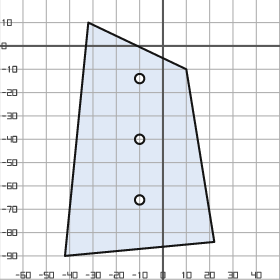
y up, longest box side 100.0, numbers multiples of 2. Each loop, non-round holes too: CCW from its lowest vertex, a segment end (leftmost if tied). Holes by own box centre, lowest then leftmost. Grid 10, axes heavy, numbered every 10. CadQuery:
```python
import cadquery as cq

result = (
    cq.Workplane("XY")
    .moveTo(-42.0, -90.0)
    .lineTo(22.0, -84.0)
    .lineTo(10.0, -10.0)
    .lineTo(-32.0, 10.0)
    .close()
    .moveTo(-10.0, -66.0)
    .circle(2.0)
    .moveTo(-10.0, -40.0)
    .circle(2.0)
    .moveTo(-10.0, -14.0)
    .circle(2.0)
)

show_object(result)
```